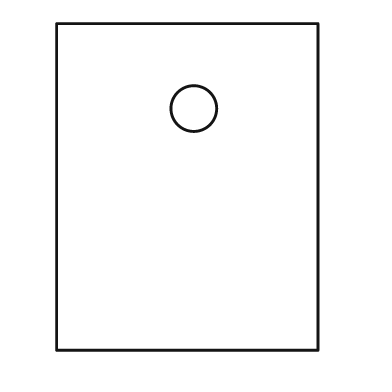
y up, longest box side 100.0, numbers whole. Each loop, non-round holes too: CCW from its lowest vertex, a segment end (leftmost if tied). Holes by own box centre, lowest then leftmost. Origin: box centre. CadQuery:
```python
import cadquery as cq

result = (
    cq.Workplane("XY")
    .moveTo(-40.0, -50.0)
    .lineTo(40.0, -50.0)
    .lineTo(40.0, 50.0)
    .lineTo(-40.0, 50.0)
    .close()
    .moveTo(2.0, 24.0)
    .circle(7.0)
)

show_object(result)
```